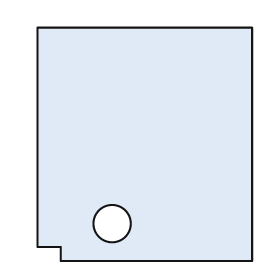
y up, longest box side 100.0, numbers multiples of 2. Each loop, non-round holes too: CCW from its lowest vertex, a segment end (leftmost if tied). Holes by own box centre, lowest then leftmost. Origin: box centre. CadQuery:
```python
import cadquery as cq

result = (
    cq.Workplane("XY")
    .moveTo(-36.0, -50.0)
    .lineTo(46.0, -50.0)
    .lineTo(46.0, 50.0)
    .lineTo(-46.0, 50.0)
    .lineTo(-46.0, -44.0)
    .lineTo(-36.0, -44.0)
    .close()
    .moveTo(-14.0, -34.0)
    .circle(8.0)
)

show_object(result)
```